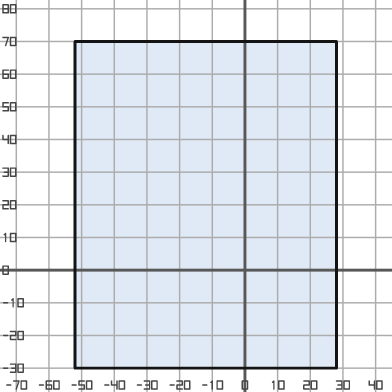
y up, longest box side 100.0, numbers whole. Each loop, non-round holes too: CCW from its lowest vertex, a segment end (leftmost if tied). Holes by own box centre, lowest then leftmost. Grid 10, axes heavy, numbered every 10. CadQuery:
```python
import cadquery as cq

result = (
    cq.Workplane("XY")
    .moveTo(-52.0, -30.0)
    .lineTo(28.0, -30.0)
    .lineTo(28.0, 70.0)
    .lineTo(-52.0, 70.0)
    .close()
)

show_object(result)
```